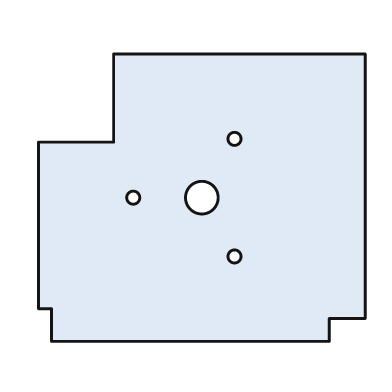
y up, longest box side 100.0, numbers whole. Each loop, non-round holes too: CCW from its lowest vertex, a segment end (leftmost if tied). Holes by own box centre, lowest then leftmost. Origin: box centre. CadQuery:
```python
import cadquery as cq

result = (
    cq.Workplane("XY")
    .moveTo(-46.0, -44.0)
    .lineTo(39.0, -44.0)
    .lineTo(39.0, -37.0)
    .lineTo(50.0, -37.0)
    .lineTo(50.0, 44.0)
    .lineTo(-27.0, 44.0)
    .lineTo(-27.0, 17.0)
    .lineTo(-50.0, 17.0)
    .lineTo(-50.0, -34.0)
    .lineTo(-46.0, -34.0)
    .close()
    .moveTo(10.0, -18.0)
    .circle(2.0)
    .moveTo(-21.0, 0.0)
    .circle(2.0)
    .moveTo(0.0, 0.0)
    .circle(5.0)
    .moveTo(10.0, 18.0)
    .circle(2.0)
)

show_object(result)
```